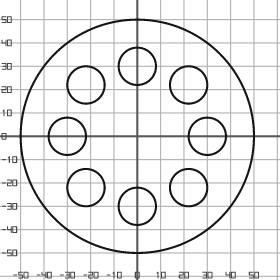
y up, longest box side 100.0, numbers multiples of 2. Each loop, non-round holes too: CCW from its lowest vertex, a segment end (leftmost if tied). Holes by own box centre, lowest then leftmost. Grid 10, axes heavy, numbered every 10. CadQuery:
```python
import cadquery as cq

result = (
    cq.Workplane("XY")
    .moveTo(0.0, 0.0)
    .circle(50.0)
    .moveTo(0.0, -30.0)
    .circle(8.0)
    .moveTo(-22.0, -22.0)
    .circle(8.0)
    .moveTo(22.0, -22.0)
    .circle(8.0)
    .moveTo(-30.0, 0.0)
    .circle(8.0)
    .moveTo(30.0, 0.0)
    .circle(8.0)
    .moveTo(-22.0, 22.0)
    .circle(8.0)
    .moveTo(22.0, 22.0)
    .circle(8.0)
    .moveTo(0.0, 30.0)
    .circle(8.0)
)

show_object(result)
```